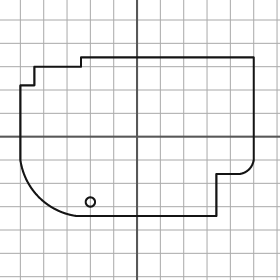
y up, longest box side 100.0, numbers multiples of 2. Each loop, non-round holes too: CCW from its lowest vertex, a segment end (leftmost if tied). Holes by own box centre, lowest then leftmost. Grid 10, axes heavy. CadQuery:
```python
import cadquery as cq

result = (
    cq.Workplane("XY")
    .moveTo(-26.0, -34.0)
    .lineTo(34.0, -34.0)
    .lineTo(34.0, -16.0)
    .lineTo(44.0, -16.0)
    .threePointArc((48.0, -14.0), (50.0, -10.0))
    .lineTo(50.0, 34.0)
    .lineTo(-24.0, 34.0)
    .lineTo(-24.0, 30.0)
    .lineTo(-44.0, 30.0)
    .lineTo(-44.0, 22.0)
    .lineTo(-50.0, 22.0)
    .lineTo(-50.0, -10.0)
    .threePointArc((-42.0, -26.0), (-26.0, -34.0))
    .close()
    .moveTo(-20.0, -28.0)
    .circle(2.0)
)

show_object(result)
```